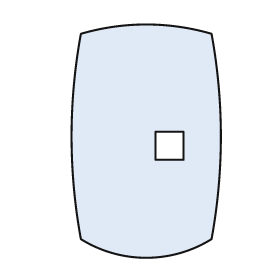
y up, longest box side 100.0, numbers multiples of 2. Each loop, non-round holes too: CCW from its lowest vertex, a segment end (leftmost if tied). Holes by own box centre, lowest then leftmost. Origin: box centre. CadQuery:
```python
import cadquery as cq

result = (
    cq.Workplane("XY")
    .moveTo(-28.0, -42.0)
    .threePointArc((0.0, -50.0), (28.0, -42.0))
    .threePointArc((32.0, 2.0), (28.0, 46.0))
    .threePointArc((0.0, 50.0), (-28.0, 46.0))
    .threePointArc((-32.0, 2.0), (-28.0, -42.0))
    .close()
    .moveTo(4.0, -8.0)
    .lineTo(16.0, -8.0)
    .lineTo(16.0, 4.0)
    .lineTo(4.0, 4.0)
    .close()
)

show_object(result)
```